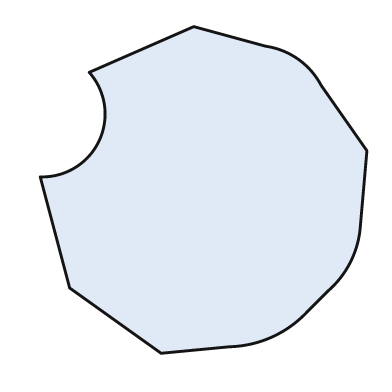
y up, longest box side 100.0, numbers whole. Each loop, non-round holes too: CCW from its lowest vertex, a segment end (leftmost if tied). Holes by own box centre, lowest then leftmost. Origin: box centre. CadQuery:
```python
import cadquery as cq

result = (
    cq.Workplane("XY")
    .moveTo(-13.0, -50.0)
    .lineTo(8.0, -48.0)
    .threePointArc((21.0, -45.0), (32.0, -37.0))
    .lineTo(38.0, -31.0)
    .threePointArc((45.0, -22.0), (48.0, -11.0))
    .lineTo(50.0, 12.0)
    .lineTo(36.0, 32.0)
    .threePointArc((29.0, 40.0), (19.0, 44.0))
    .lineTo(-3.0, 50.0)
    .lineTo(-35.0, 36.0)
    .threePointArc((-32.0, 15.0), (-50.0, 4.0))
    .lineTo(-41.0, -30.0)
    .close()
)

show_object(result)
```